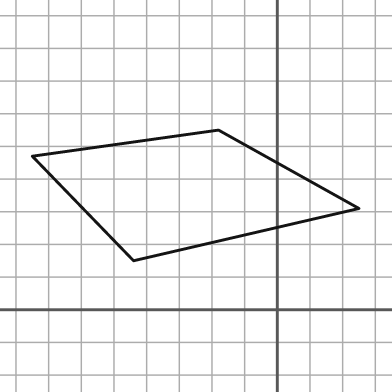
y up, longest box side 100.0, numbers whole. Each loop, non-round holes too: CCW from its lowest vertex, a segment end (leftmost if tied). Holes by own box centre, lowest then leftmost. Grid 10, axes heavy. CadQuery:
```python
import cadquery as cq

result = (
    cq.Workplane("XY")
    .moveTo(-44.0, 15.0)
    .lineTo(25.0, 31.0)
    .lineTo(-18.0, 55.0)
    .lineTo(-75.0, 47.0)
    .close()
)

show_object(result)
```